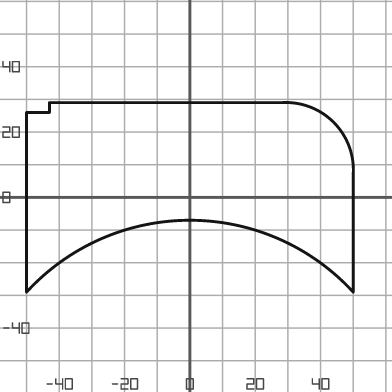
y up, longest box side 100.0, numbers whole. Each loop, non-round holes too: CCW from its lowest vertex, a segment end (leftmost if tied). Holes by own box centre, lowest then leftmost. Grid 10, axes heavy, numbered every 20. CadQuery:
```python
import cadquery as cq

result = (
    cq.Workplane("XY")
    .moveTo(-50.0, -29.0)
    .threePointArc((0.0, -7.0), (50.0, -29.0))
    .lineTo(50.0, 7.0)
    .threePointArc((44.0, 23.0), (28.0, 29.0))
    .lineTo(-43.0, 29.0)
    .lineTo(-43.0, 26.0)
    .lineTo(-50.0, 26.0)
    .close()
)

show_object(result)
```